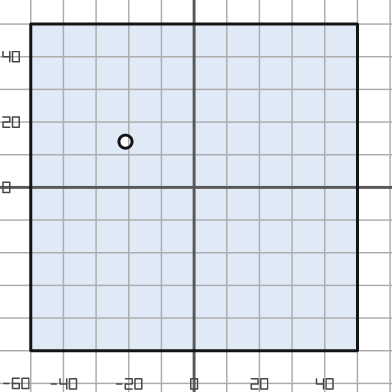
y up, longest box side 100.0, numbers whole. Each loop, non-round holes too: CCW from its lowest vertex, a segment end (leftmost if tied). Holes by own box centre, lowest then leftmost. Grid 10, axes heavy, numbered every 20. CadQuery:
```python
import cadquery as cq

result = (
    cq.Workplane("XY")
    .moveTo(-50.0, -50.0)
    .lineTo(50.0, -50.0)
    .lineTo(50.0, 50.0)
    .lineTo(-50.0, 50.0)
    .close()
    .moveTo(-21.0, 14.0)
    .circle(2.0)
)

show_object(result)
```